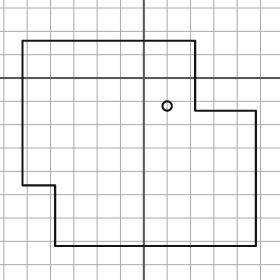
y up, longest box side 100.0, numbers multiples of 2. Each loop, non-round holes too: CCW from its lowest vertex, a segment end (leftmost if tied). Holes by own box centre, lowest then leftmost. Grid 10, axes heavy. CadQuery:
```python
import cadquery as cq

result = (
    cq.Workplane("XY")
    .moveTo(-38.0, -72.0)
    .lineTo(48.0, -72.0)
    .lineTo(48.0, -14.0)
    .lineTo(22.0, -14.0)
    .lineTo(22.0, 16.0)
    .lineTo(-52.0, 16.0)
    .lineTo(-52.0, -46.0)
    .lineTo(-38.0, -46.0)
    .close()
    .moveTo(10.0, -12.0)
    .circle(2.0)
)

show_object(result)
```